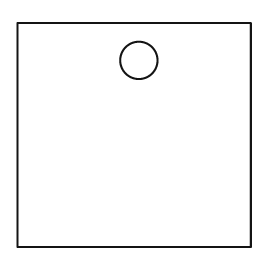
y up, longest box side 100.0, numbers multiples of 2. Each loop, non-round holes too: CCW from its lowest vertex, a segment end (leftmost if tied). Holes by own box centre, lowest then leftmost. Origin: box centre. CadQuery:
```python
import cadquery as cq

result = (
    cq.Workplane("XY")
    .moveTo(-50.0, -48.0)
    .lineTo(50.0, -48.0)
    .lineTo(50.0, 48.0)
    .lineTo(-50.0, 48.0)
    .close()
    .moveTo(2.0, 32.0)
    .circle(8.0)
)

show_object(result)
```